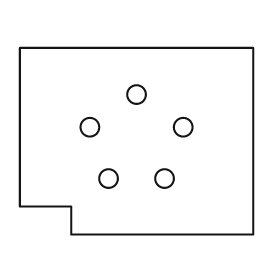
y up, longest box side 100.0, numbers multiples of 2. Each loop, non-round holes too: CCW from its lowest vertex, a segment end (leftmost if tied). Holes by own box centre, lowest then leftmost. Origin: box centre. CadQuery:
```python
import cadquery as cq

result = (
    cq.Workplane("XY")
    .moveTo(-28.0, -40.0)
    .lineTo(50.0, -40.0)
    .lineTo(50.0, 40.0)
    .lineTo(-50.0, 40.0)
    .lineTo(-50.0, -28.0)
    .lineTo(-28.0, -28.0)
    .close()
    .moveTo(-12.0, -16.0)
    .circle(4.0)
    .moveTo(12.0, -16.0)
    .circle(4.0)
    .moveTo(-20.0, 6.0)
    .circle(4.0)
    .moveTo(20.0, 6.0)
    .circle(4.0)
    .moveTo(0.0, 20.0)
    .circle(4.0)
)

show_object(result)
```